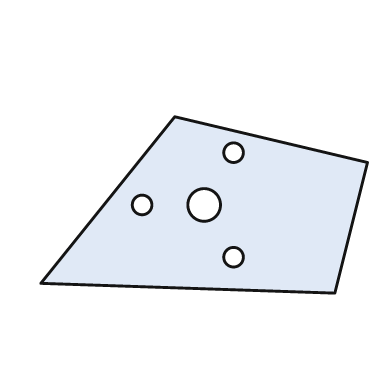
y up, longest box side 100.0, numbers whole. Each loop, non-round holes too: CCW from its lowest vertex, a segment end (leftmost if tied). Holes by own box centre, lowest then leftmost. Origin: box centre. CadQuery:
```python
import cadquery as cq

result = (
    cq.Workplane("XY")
    .moveTo(40.0, -27.0)
    .lineTo(50.0, 13.0)
    .lineTo(-9.0, 27.0)
    .lineTo(-50.0, -24.0)
    .close()
    .moveTo(9.0, -16.0)
    .circle(3.0)
    .moveTo(-19.0, 0.0)
    .circle(3.0)
    .moveTo(0.0, 0.0)
    .circle(5.0)
    .moveTo(9.0, 16.0)
    .circle(3.0)
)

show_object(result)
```